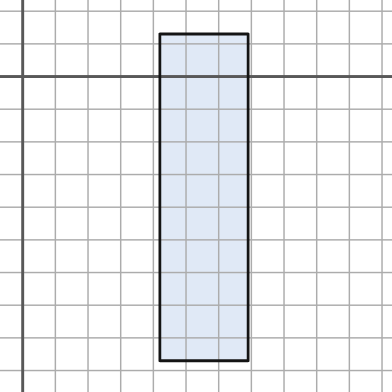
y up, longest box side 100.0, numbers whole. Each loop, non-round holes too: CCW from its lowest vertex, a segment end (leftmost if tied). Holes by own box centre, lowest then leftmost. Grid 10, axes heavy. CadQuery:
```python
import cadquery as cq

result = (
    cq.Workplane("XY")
    .moveTo(42.0, -87.0)
    .lineTo(69.0, -87.0)
    .lineTo(69.0, 13.0)
    .lineTo(42.0, 13.0)
    .close()
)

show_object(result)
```